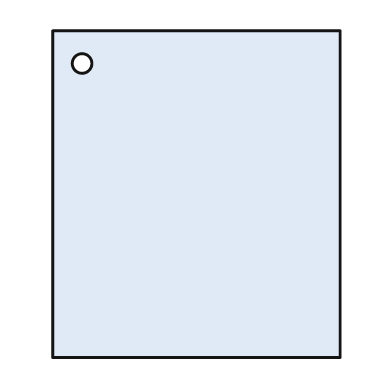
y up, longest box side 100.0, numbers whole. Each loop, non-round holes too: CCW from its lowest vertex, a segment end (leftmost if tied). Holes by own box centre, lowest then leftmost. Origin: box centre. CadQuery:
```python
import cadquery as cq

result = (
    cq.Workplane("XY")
    .moveTo(-44.0, -50.0)
    .lineTo(44.0, -50.0)
    .lineTo(44.0, 50.0)
    .lineTo(-44.0, 50.0)
    .close()
    .moveTo(-35.0, 40.0)
    .circle(3.0)
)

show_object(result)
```